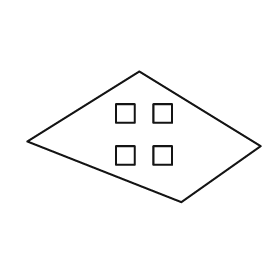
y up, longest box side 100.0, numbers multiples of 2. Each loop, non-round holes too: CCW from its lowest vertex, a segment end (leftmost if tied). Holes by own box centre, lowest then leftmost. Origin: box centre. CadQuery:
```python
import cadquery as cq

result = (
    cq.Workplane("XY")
    .moveTo(16.0, -28.0)
    .lineTo(50.0, -4.0)
    .lineTo(-2.0, 28.0)
    .lineTo(-50.0, -2.0)
    .close()
    .moveTo(-12.0, -12.0)
    .lineTo(-4.0, -12.0)
    .lineTo(-4.0, -4.0)
    .lineTo(-12.0, -4.0)
    .close()
    .moveTo(4.0, -12.0)
    .lineTo(12.0, -12.0)
    .lineTo(12.0, -4.0)
    .lineTo(4.0, -4.0)
    .close()
    .moveTo(-12.0, 6.0)
    .lineTo(-4.0, 6.0)
    .lineTo(-4.0, 14.0)
    .lineTo(-12.0, 14.0)
    .close()
    .moveTo(4.0, 6.0)
    .lineTo(12.0, 6.0)
    .lineTo(12.0, 14.0)
    .lineTo(4.0, 14.0)
    .close()
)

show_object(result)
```